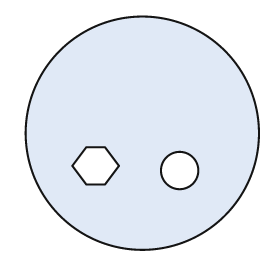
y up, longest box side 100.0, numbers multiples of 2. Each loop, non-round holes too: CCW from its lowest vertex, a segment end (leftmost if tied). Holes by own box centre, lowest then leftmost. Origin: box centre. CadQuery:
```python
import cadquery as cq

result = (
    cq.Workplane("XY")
    .moveTo(0.0, 0.0)
    .circle(50.0)
    .moveTo(16.0, -16.0)
    .circle(8.0)
    .moveTo(-24.0, -22.0)
    .lineTo(-16.0, -22.0)
    .lineTo(-10.0, -14.0)
    .lineTo(-16.0, -6.0)
    .lineTo(-24.0, -6.0)
    .lineTo(-30.0, -14.0)
    .close()
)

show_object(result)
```